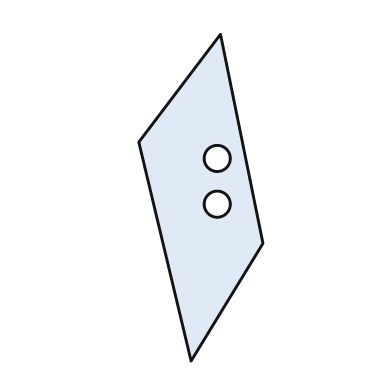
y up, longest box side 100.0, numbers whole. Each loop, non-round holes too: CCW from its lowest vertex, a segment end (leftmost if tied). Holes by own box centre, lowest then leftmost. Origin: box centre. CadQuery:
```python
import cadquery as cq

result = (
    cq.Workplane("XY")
    .moveTo(-3.0, -50.0)
    .lineTo(19.0, -14.0)
    .lineTo(6.0, 50.0)
    .lineTo(-19.0, 17.0)
    .close()
    .moveTo(5.0, -2.0)
    .circle(4.0)
    .moveTo(5.0, 12.0)
    .circle(4.0)
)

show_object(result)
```